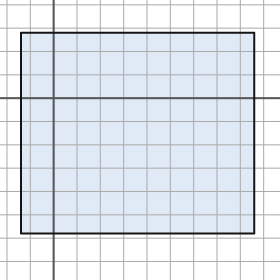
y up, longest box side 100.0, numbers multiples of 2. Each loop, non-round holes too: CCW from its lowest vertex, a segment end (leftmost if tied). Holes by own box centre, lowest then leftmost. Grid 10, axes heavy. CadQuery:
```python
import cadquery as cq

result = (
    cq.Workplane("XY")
    .moveTo(-14.0, -58.0)
    .lineTo(86.0, -58.0)
    .lineTo(86.0, 28.0)
    .lineTo(-14.0, 28.0)
    .close()
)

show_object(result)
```